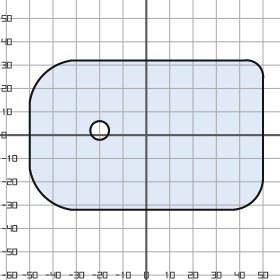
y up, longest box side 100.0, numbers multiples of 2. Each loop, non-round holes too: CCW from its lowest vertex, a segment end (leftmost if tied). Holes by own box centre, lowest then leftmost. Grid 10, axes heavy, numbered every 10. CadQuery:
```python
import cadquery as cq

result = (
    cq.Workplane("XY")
    .moveTo(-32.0, -32.0)
    .lineTo(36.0, -32.0)
    .threePointArc((46.0, -28.0), (50.0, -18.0))
    .lineTo(50.0, 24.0)
    .threePointArc((48.0, 30.0), (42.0, 32.0))
    .lineTo(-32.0, 32.0)
    .threePointArc((-44.0, 26.0), (-50.0, 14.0))
    .lineTo(-50.0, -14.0)
    .threePointArc((-44.0, -26.0), (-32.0, -32.0))
    .close()
    .moveTo(-20.0, 2.0)
    .circle(4.0)
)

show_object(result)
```